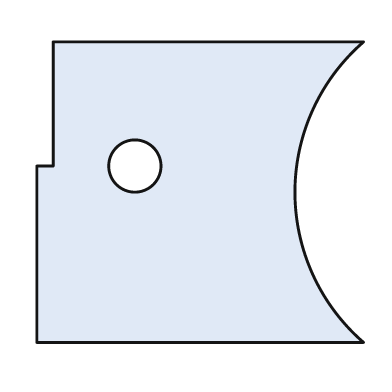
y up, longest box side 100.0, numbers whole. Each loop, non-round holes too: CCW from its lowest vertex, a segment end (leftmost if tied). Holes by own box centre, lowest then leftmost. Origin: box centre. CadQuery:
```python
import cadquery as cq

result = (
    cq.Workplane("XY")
    .moveTo(-50.0, -46.0)
    .lineTo(50.0, -46.0)
    .threePointArc((29.0, 0.0), (50.0, 46.0))
    .lineTo(-45.0, 46.0)
    .lineTo(-45.0, 8.0)
    .lineTo(-50.0, 8.0)
    .close()
    .moveTo(-20.0, 8.0)
    .circle(8.0)
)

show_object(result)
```